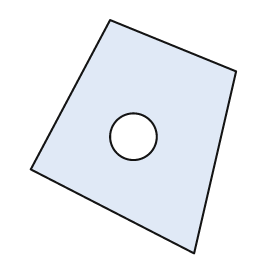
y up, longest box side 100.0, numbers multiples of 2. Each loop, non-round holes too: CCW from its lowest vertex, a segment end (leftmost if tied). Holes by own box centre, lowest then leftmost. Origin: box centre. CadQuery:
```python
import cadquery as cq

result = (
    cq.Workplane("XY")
    .moveTo(26.0, -50.0)
    .lineTo(44.0, 28.0)
    .lineTo(-10.0, 50.0)
    .lineTo(-44.0, -14.0)
    .close()
    .moveTo(0.0, 0.0)
    .circle(10.0)
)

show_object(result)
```